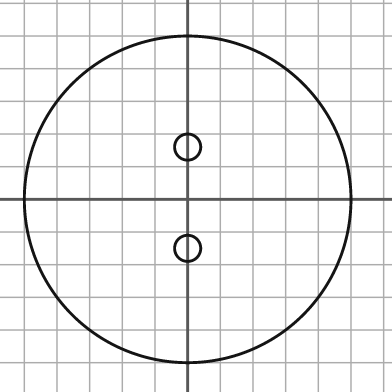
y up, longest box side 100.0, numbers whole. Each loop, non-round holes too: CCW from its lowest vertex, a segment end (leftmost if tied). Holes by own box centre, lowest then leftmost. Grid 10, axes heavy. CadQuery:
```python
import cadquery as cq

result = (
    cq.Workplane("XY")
    .moveTo(0.0, 0.0)
    .circle(50.0)
    .moveTo(0.0, -15.0)
    .circle(4.0)
    .moveTo(0.0, 16.0)
    .circle(4.0)
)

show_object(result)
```